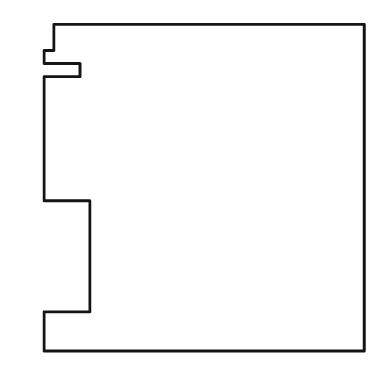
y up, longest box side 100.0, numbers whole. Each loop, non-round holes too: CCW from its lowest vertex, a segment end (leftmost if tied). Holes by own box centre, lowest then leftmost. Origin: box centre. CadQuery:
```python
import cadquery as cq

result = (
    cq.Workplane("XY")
    .moveTo(-49.0, -50.0)
    .lineTo(49.0, -50.0)
    .lineTo(49.0, 50.0)
    .lineTo(-46.0, 50.0)
    .lineTo(-46.0, 42.0)
    .lineTo(-49.0, 42.0)
    .lineTo(-49.0, 38.0)
    .lineTo(-38.0, 38.0)
    .lineTo(-38.0, 34.0)
    .lineTo(-49.0, 34.0)
    .lineTo(-49.0, -4.0)
    .lineTo(-35.0, -4.0)
    .lineTo(-35.0, -38.0)
    .lineTo(-49.0, -38.0)
    .close()
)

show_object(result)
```